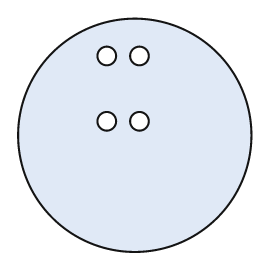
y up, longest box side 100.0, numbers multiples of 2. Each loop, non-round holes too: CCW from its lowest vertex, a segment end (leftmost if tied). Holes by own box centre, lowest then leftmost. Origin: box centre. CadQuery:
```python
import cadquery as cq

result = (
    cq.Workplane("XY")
    .moveTo(0.0, 0.0)
    .circle(50.0)
    .moveTo(-12.0, 6.0)
    .circle(4.0)
    .moveTo(2.0, 6.0)
    .circle(4.0)
    .moveTo(-12.0, 34.0)
    .circle(4.0)
    .moveTo(2.0, 34.0)
    .circle(4.0)
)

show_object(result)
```